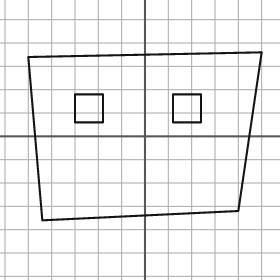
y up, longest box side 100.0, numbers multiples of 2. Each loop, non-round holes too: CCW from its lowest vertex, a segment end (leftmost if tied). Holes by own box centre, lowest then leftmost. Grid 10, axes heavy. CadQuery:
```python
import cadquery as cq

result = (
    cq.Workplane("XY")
    .moveTo(-44.0, -36.0)
    .lineTo(40.0, -32.0)
    .lineTo(50.0, 36.0)
    .lineTo(-50.0, 34.0)
    .close()
    .moveTo(-30.0, 6.0)
    .lineTo(-18.0, 6.0)
    .lineTo(-18.0, 18.0)
    .lineTo(-30.0, 18.0)
    .close()
    .moveTo(12.0, 6.0)
    .lineTo(24.0, 6.0)
    .lineTo(24.0, 18.0)
    .lineTo(12.0, 18.0)
    .close()
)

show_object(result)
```